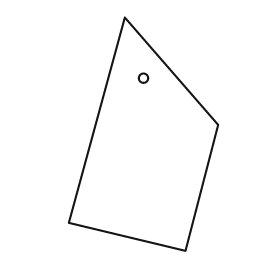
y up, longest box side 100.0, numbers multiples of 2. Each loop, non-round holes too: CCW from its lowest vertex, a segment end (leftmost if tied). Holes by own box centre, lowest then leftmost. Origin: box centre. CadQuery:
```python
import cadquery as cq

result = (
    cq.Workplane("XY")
    .moveTo(18.0, -50.0)
    .lineTo(32.0, 4.0)
    .lineTo(-8.0, 50.0)
    .lineTo(-32.0, -38.0)
    .close()
    .moveTo(0.0, 24.0)
    .circle(2.0)
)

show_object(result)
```